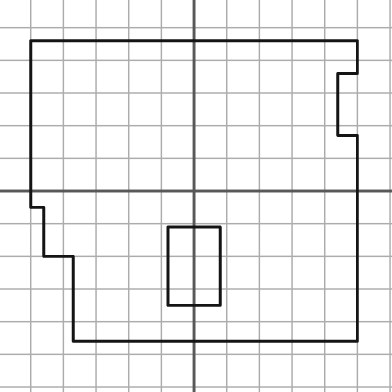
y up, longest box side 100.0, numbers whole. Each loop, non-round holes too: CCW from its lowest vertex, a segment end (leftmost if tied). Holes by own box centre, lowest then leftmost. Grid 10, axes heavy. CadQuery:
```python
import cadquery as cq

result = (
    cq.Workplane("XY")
    .moveTo(-37.0, -46.0)
    .lineTo(50.0, -46.0)
    .lineTo(50.0, 17.0)
    .lineTo(44.0, 17.0)
    .lineTo(44.0, 36.0)
    .lineTo(50.0, 36.0)
    .lineTo(50.0, 46.0)
    .lineTo(-50.0, 46.0)
    .lineTo(-50.0, -5.0)
    .lineTo(-46.0, -5.0)
    .lineTo(-46.0, -20.0)
    .lineTo(-37.0, -20.0)
    .close()
    .moveTo(-8.0, -35.0)
    .lineTo(8.0, -35.0)
    .lineTo(8.0, -11.0)
    .lineTo(-8.0, -11.0)
    .close()
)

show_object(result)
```